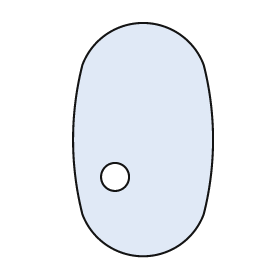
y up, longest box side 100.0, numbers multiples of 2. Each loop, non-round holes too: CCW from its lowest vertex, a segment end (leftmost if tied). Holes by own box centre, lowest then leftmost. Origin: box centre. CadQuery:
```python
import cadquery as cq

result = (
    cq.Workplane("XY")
    .moveTo(-26.0, -32.0)
    .threePointArc((0.0, -50.0), (26.0, -32.0))
    .threePointArc((30.0, 0.0), (26.0, 32.0))
    .threePointArc((0.0, 50.0), (-26.0, 32.0))
    .threePointArc((-30.0, 0.0), (-26.0, -32.0))
    .close()
    .moveTo(-12.0, -16.0)
    .circle(6.0)
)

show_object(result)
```